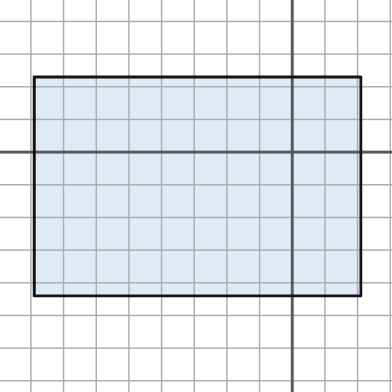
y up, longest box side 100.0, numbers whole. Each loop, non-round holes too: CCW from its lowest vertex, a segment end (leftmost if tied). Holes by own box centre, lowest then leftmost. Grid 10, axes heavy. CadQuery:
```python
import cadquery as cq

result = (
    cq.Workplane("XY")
    .moveTo(-79.0, -44.0)
    .lineTo(21.0, -44.0)
    .lineTo(21.0, 23.0)
    .lineTo(-79.0, 23.0)
    .close()
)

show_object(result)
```